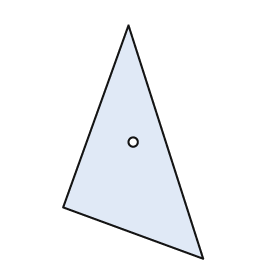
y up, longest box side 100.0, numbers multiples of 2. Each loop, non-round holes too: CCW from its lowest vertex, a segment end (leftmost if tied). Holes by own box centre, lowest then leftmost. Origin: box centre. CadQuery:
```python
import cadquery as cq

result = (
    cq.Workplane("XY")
    .moveTo(30.0, -50.0)
    .lineTo(-2.0, 50.0)
    .lineTo(-30.0, -28.0)
    .close()
    .moveTo(0.0, 0.0)
    .circle(2.0)
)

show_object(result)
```